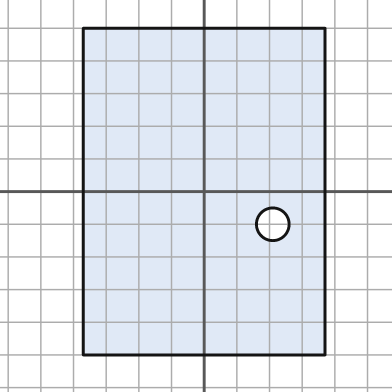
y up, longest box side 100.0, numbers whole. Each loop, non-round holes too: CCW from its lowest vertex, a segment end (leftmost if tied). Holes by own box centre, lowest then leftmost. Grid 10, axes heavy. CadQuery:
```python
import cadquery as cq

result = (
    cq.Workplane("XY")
    .moveTo(-37.0, -50.0)
    .lineTo(37.0, -50.0)
    .lineTo(37.0, 50.0)
    .lineTo(-37.0, 50.0)
    .close()
    .moveTo(21.0, -10.0)
    .circle(5.0)
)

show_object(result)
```